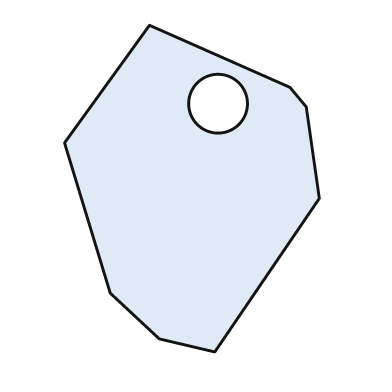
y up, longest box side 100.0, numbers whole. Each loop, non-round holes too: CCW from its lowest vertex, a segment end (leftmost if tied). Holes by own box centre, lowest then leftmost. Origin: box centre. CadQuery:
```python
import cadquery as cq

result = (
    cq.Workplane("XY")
    .moveTo(7.0, -50.0)
    .lineTo(39.0, -3.0)
    .lineTo(35.0, 25.0)
    .lineTo(30.0, 31.0)
    .lineTo(-13.0, 50.0)
    .lineTo(-39.0, 14.0)
    .lineTo(-25.0, -32.0)
    .lineTo(-10.0, -46.0)
    .close()
    .moveTo(8.0, 26.0)
    .circle(9.0)
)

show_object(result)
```